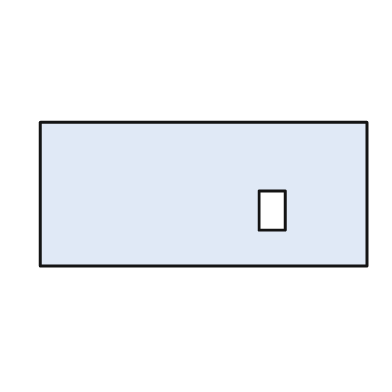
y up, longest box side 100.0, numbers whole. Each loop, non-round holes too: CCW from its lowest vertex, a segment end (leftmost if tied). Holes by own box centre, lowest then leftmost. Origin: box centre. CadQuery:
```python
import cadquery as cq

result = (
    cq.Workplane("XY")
    .moveTo(-50.0, -22.0)
    .lineTo(50.0, -22.0)
    .lineTo(50.0, 22.0)
    .lineTo(-50.0, 22.0)
    .close()
    .moveTo(17.0, -11.0)
    .lineTo(25.0, -11.0)
    .lineTo(25.0, 1.0)
    .lineTo(17.0, 1.0)
    .close()
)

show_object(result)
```